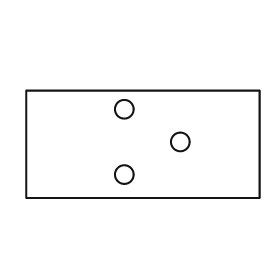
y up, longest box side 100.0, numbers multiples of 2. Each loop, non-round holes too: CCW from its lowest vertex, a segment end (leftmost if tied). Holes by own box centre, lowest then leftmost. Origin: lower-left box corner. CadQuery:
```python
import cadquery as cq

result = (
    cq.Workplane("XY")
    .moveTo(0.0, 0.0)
    .lineTo(100.0, 0.0)
    .lineTo(100.0, 46.0)
    .lineTo(0.0, 46.0)
    .close()
    .moveTo(42.0, 10.0)
    .circle(4.0)
    .moveTo(66.0, 24.0)
    .circle(4.0)
    .moveTo(42.0, 38.0)
    .circle(4.0)
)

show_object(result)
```